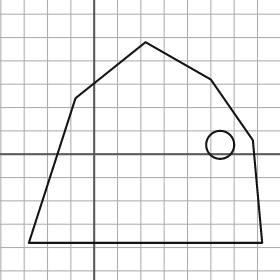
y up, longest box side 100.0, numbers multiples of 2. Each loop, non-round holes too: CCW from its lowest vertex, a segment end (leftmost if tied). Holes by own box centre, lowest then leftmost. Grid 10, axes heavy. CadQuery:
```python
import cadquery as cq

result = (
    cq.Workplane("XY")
    .moveTo(-28.0, -38.0)
    .lineTo(72.0, -38.0)
    .lineTo(68.0, 6.0)
    .lineTo(50.0, 32.0)
    .lineTo(22.0, 48.0)
    .lineTo(-8.0, 24.0)
    .close()
    .moveTo(54.0, 4.0)
    .circle(6.0)
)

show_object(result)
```